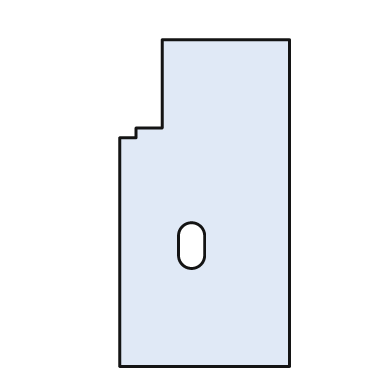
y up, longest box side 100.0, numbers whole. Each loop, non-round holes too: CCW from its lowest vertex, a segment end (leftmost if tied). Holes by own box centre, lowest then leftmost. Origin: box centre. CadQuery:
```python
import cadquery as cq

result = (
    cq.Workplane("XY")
    .moveTo(-26.0, -50.0)
    .lineTo(26.0, -50.0)
    .lineTo(26.0, 50.0)
    .lineTo(-13.0, 50.0)
    .lineTo(-13.0, 23.0)
    .lineTo(-21.0, 23.0)
    .lineTo(-21.0, 20.0)
    .lineTo(-26.0, 20.0)
    .close()
    .moveTo(-8.0, -16.0)
    .threePointArc((-4.0, -20.0), (0.0, -16.0))
    .lineTo(0.0, -10.0)
    .threePointArc((-4.0, -6.0), (-8.0, -10.0))
    .close()
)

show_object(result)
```